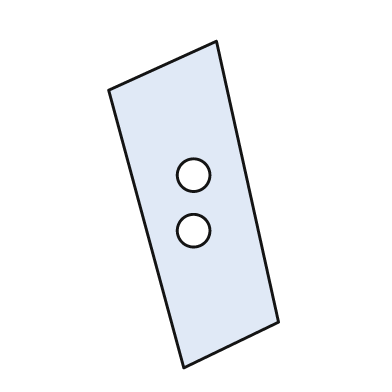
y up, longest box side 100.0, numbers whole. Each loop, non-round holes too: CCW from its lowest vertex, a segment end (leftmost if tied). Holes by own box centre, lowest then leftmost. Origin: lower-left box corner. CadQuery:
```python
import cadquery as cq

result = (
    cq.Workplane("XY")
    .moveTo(23.0, 0.0)
    .lineTo(52.0, 14.0)
    .lineTo(33.0, 100.0)
    .lineTo(0.0, 85.0)
    .close()
    .moveTo(26.0, 42.0)
    .circle(5.0)
    .moveTo(26.0, 59.0)
    .circle(5.0)
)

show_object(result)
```